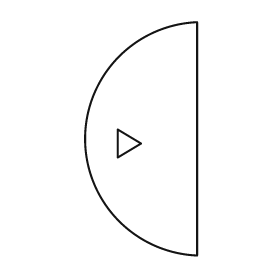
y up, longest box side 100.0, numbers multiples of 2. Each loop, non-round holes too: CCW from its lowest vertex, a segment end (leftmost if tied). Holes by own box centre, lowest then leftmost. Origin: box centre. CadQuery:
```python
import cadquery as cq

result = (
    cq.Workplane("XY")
    .moveTo(24.0, -50.0)
    .lineTo(24.0, 50.0)
    .threePointArc((-24.0, 0.0), (24.0, -50.0))
    .close()
    .moveTo(-10.0, -8.0)
    .lineTo(0.0, -2.0)
    .lineTo(-10.0, 4.0)
    .close()
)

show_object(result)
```